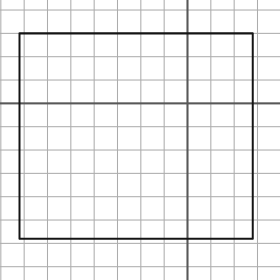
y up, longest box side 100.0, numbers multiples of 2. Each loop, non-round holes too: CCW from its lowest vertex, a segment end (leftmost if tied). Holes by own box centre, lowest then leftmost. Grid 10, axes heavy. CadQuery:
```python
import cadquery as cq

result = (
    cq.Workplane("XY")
    .moveTo(-72.0, -58.0)
    .lineTo(28.0, -58.0)
    .lineTo(28.0, 30.0)
    .lineTo(-72.0, 30.0)
    .close()
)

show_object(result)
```